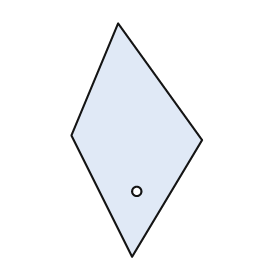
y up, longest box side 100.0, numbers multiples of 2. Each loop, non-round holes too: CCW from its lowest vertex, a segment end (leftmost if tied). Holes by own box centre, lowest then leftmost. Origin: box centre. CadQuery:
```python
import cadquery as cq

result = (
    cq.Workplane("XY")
    .moveTo(-2.0, -50.0)
    .lineTo(28.0, 0.0)
    .lineTo(-8.0, 50.0)
    .lineTo(-28.0, 2.0)
    .close()
    .moveTo(0.0, -22.0)
    .circle(2.0)
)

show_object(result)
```